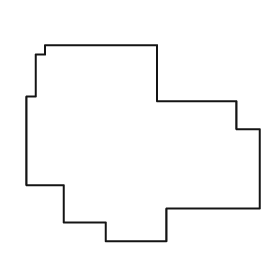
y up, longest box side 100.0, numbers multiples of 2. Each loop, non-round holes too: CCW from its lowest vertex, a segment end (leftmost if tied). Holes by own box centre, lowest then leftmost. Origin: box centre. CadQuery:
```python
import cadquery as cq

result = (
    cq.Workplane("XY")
    .moveTo(-16.0, -42.0)
    .lineTo(10.0, -42.0)
    .lineTo(10.0, -28.0)
    .lineTo(50.0, -28.0)
    .lineTo(50.0, 6.0)
    .lineTo(40.0, 6.0)
    .lineTo(40.0, 18.0)
    .lineTo(6.0, 18.0)
    .lineTo(6.0, 42.0)
    .lineTo(-42.0, 42.0)
    .lineTo(-42.0, 38.0)
    .lineTo(-46.0, 38.0)
    .lineTo(-46.0, 20.0)
    .lineTo(-50.0, 20.0)
    .lineTo(-50.0, -18.0)
    .lineTo(-34.0, -18.0)
    .lineTo(-34.0, -34.0)
    .lineTo(-16.0, -34.0)
    .close()
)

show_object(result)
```